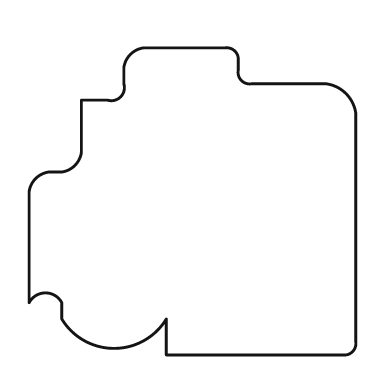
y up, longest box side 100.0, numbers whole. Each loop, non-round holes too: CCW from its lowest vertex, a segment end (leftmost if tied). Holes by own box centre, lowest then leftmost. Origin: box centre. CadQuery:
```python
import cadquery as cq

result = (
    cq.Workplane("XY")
    .moveTo(-8.0, -47.0)
    .lineTo(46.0, -47.0)
    .threePointArc((49.0, -46.0), (50.0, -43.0))
    .lineTo(50.0, 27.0)
    .threePointArc((47.0, 33.0), (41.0, 36.0))
    .lineTo(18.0, 36.0)
    .threePointArc((15.0, 37.0), (14.0, 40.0))
    .lineTo(14.0, 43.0)
    .threePointArc((13.0, 46.0), (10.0, 47.0))
    .lineTo(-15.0, 47.0)
    .threePointArc((-19.0, 45.0), (-21.0, 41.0))
    .lineTo(-21.0, 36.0)
    .threePointArc((-22.0, 32.0), (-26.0, 31.0))
    .lineTo(-34.0, 31.0)
    .lineTo(-34.0, 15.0)
    .threePointArc((-36.0, 11.0), (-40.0, 9.0))
    .lineTo(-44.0, 9.0)
    .threePointArc((-48.0, 7.0), (-50.0, 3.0))
    .lineTo(-50.0, -31.0)
    .threePointArc((-45.0, -28.0), (-40.0, -31.0))
    .lineTo(-40.0, -36.0)
    .threePointArc((-24.0, -45.0), (-8.0, -36.0))
    .close()
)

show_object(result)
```